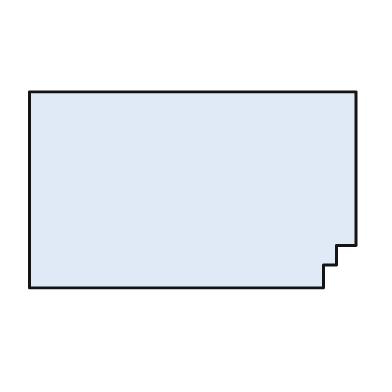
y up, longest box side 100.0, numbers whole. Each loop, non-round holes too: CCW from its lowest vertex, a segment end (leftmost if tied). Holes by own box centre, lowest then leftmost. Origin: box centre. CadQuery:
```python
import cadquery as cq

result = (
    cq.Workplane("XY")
    .moveTo(-50.0, -30.0)
    .lineTo(40.0, -30.0)
    .lineTo(40.0, -23.0)
    .lineTo(44.0, -23.0)
    .lineTo(44.0, -17.0)
    .lineTo(50.0, -17.0)
    .lineTo(50.0, 30.0)
    .lineTo(-50.0, 30.0)
    .close()
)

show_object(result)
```